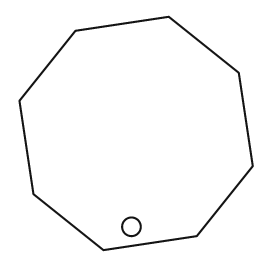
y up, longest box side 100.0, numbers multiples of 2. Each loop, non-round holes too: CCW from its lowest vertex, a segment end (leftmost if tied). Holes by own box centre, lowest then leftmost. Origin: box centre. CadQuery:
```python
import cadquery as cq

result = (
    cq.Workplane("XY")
    .moveTo(-14.0, -50.0)
    .lineTo(26.0, -44.0)
    .lineTo(50.0, -14.0)
    .lineTo(44.0, 26.0)
    .lineTo(14.0, 50.0)
    .lineTo(-26.0, 44.0)
    .lineTo(-50.0, 14.0)
    .lineTo(-44.0, -26.0)
    .close()
    .moveTo(-2.0, -40.0)
    .circle(4.0)
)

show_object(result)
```